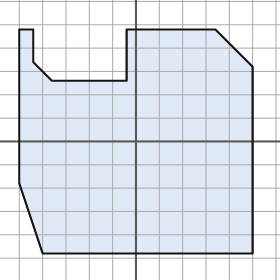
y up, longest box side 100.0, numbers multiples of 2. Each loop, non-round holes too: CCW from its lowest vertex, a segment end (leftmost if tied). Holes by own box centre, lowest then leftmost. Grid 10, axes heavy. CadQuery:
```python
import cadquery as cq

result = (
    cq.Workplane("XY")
    .moveTo(-40.0, -48.0)
    .lineTo(50.0, -48.0)
    .lineTo(50.0, 32.0)
    .lineTo(34.0, 48.0)
    .lineTo(-4.0, 48.0)
    .lineTo(-4.0, 26.0)
    .lineTo(-36.0, 26.0)
    .lineTo(-44.0, 34.0)
    .lineTo(-44.0, 48.0)
    .lineTo(-50.0, 48.0)
    .lineTo(-50.0, -18.0)
    .close()
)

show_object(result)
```